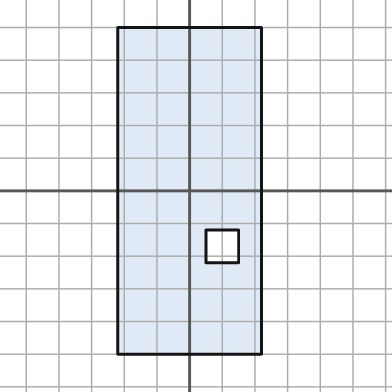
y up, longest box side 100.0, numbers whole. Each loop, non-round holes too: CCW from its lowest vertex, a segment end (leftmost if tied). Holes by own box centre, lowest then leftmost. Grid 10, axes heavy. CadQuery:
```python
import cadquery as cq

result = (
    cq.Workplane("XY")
    .moveTo(-22.0, -50.0)
    .lineTo(22.0, -50.0)
    .lineTo(22.0, 50.0)
    .lineTo(-22.0, 50.0)
    .close()
    .moveTo(5.0, -22.0)
    .lineTo(15.0, -22.0)
    .lineTo(15.0, -12.0)
    .lineTo(5.0, -12.0)
    .close()
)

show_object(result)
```